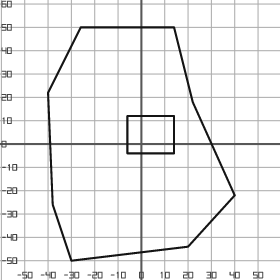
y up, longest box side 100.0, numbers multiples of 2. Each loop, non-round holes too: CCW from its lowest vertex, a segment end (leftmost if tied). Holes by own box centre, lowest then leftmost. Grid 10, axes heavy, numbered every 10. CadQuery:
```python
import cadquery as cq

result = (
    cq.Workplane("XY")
    .moveTo(-30.0, -50.0)
    .lineTo(20.0, -44.0)
    .lineTo(40.0, -22.0)
    .lineTo(22.0, 18.0)
    .lineTo(14.0, 50.0)
    .lineTo(-26.0, 50.0)
    .lineTo(-40.0, 22.0)
    .lineTo(-38.0, -26.0)
    .close()
    .moveTo(-6.0, -4.0)
    .lineTo(14.0, -4.0)
    .lineTo(14.0, 12.0)
    .lineTo(-6.0, 12.0)
    .close()
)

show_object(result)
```